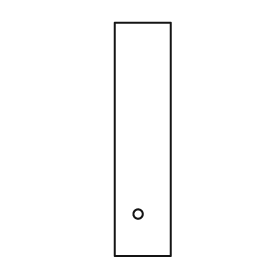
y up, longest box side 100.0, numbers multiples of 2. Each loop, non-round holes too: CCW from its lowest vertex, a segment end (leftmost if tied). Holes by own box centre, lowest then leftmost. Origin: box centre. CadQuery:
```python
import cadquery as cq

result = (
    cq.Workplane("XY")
    .moveTo(-12.0, -50.0)
    .lineTo(12.0, -50.0)
    .lineTo(12.0, 50.0)
    .lineTo(-12.0, 50.0)
    .close()
    .moveTo(-2.0, -32.0)
    .circle(2.0)
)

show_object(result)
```